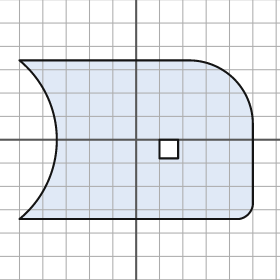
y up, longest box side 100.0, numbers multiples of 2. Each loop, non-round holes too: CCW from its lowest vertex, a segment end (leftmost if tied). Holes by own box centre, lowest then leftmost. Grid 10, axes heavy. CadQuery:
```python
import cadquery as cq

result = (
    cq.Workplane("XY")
    .moveTo(-50.0, -34.0)
    .lineTo(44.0, -34.0)
    .threePointArc((48.0, -32.0), (50.0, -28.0))
    .lineTo(50.0, 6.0)
    .threePointArc((42.0, 26.0), (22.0, 34.0))
    .lineTo(-50.0, 34.0)
    .threePointArc((-34.0, 0.0), (-50.0, -34.0))
    .close()
    .moveTo(10.0, -8.0)
    .lineTo(18.0, -8.0)
    .lineTo(18.0, 0.0)
    .lineTo(10.0, 0.0)
    .close()
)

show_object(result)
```